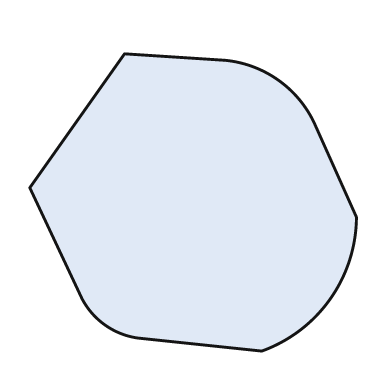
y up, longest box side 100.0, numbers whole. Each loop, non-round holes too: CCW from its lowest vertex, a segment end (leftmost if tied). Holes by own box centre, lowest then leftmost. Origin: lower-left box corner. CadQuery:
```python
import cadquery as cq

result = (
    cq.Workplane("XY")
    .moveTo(71.0, 0.0)
    .threePointArc((92.0, 16.0), (100.0, 41.0))
    .lineTo(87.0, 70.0)
    .threePointArc((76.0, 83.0), (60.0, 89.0))
    .lineTo(29.0, 91.0)
    .lineTo(0.0, 50.0)
    .lineTo(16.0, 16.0)
    .threePointArc((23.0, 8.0), (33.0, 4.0))
    .close()
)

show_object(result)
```